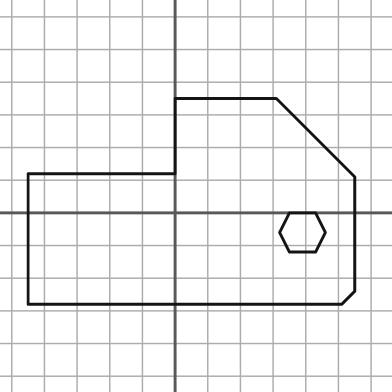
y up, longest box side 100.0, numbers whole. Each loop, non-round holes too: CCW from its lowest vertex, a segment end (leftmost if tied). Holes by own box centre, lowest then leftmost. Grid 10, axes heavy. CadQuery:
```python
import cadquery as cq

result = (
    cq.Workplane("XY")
    .moveTo(-45.0, -28.0)
    .lineTo(51.0, -28.0)
    .lineTo(55.0, -24.0)
    .lineTo(55.0, 11.0)
    .lineTo(31.0, 35.0)
    .lineTo(0.0, 35.0)
    .lineTo(0.0, 12.0)
    .lineTo(-45.0, 12.0)
    .close()
    .moveTo(35.0, -12.0)
    .lineTo(43.0, -12.0)
    .lineTo(46.0, -6.0)
    .lineTo(43.0, 0.0)
    .lineTo(35.0, 0.0)
    .lineTo(32.0, -6.0)
    .close()
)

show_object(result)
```